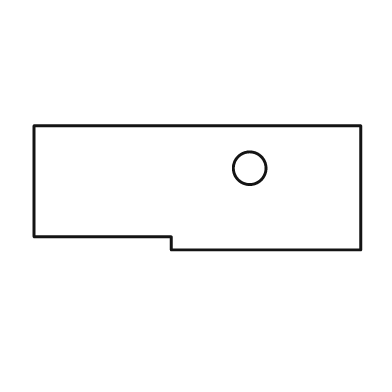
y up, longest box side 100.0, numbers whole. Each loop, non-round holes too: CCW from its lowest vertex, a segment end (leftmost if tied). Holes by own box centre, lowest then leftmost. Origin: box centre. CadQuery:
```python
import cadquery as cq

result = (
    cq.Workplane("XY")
    .moveTo(-8.0, -19.0)
    .lineTo(50.0, -19.0)
    .lineTo(50.0, 19.0)
    .lineTo(-50.0, 19.0)
    .lineTo(-50.0, -15.0)
    .lineTo(-8.0, -15.0)
    .close()
    .moveTo(16.0, 6.0)
    .circle(5.0)
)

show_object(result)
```